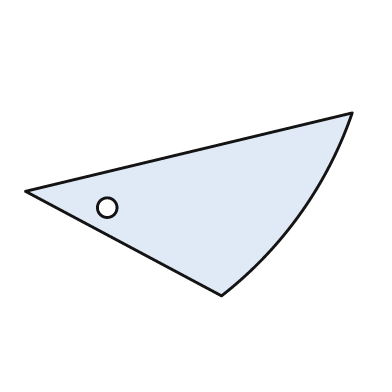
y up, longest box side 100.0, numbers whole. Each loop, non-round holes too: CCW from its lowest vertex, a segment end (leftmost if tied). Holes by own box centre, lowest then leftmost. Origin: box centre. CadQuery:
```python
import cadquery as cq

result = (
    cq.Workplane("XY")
    .moveTo(10.0, -28.0)
    .threePointArc((34.0, -3.0), (50.0, 28.0))
    .lineTo(-50.0, 4.0)
    .close()
    .moveTo(-25.0, -1.0)
    .circle(3.0)
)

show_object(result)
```